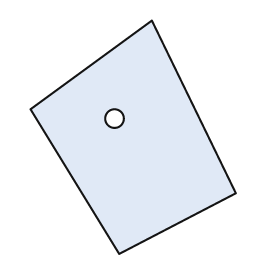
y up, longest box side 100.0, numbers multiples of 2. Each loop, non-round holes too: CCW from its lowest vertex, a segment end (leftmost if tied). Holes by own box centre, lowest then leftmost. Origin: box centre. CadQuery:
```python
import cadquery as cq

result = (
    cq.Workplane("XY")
    .moveTo(-6.0, -50.0)
    .lineTo(44.0, -24.0)
    .lineTo(8.0, 50.0)
    .lineTo(-44.0, 12.0)
    .close()
    .moveTo(-8.0, 8.0)
    .circle(4.0)
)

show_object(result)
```